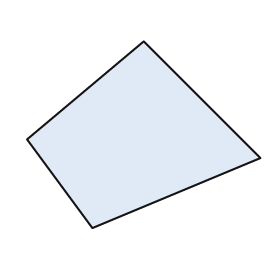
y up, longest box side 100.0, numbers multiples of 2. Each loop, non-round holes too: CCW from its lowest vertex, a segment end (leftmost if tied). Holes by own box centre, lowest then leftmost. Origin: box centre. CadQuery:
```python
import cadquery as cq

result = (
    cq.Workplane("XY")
    .moveTo(-22.0, -40.0)
    .lineTo(50.0, -10.0)
    .lineTo(0.0, 40.0)
    .lineTo(-50.0, -2.0)
    .close()
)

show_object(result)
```